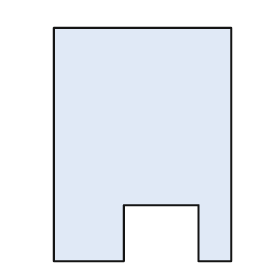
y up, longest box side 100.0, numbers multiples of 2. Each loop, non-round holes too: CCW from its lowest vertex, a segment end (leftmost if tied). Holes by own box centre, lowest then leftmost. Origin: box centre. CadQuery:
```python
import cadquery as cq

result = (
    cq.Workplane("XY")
    .moveTo(-38.0, -50.0)
    .lineTo(-8.0, -50.0)
    .lineTo(-8.0, -26.0)
    .lineTo(24.0, -26.0)
    .lineTo(24.0, -50.0)
    .lineTo(38.0, -50.0)
    .lineTo(38.0, 50.0)
    .lineTo(-38.0, 50.0)
    .close()
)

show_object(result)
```